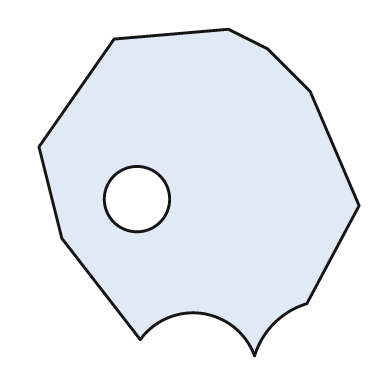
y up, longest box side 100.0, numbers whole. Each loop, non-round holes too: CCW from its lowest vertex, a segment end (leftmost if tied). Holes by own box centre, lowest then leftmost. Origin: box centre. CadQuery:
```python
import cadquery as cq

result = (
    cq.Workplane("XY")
    .moveTo(17.0, -50.0)
    .threePointArc((23.0, -40.0), (33.0, -34.0))
    .lineTo(49.0, -4.0)
    .lineTo(34.0, 31.0)
    .lineTo(21.0, 44.0)
    .lineTo(9.0, 50.0)
    .lineTo(-26.0, 47.0)
    .lineTo(-49.0, 14.0)
    .lineTo(-42.0, -14.0)
    .lineTo(-18.0, -45.0)
    .threePointArc((1.0, -37.0), (17.0, -50.0))
    .close()
    .moveTo(-19.0, -2.0)
    .circle(10.0)
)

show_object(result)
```